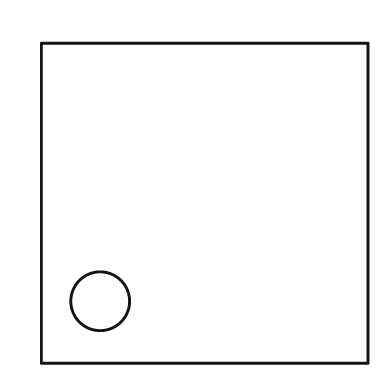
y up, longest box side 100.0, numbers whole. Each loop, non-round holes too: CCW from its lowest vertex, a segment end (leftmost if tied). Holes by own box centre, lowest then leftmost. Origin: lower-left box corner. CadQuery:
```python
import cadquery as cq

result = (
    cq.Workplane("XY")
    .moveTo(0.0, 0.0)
    .lineTo(100.0, 0.0)
    .lineTo(100.0, 98.0)
    .lineTo(0.0, 98.0)
    .close()
    .moveTo(18.0, 19.0)
    .circle(9.0)
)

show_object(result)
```